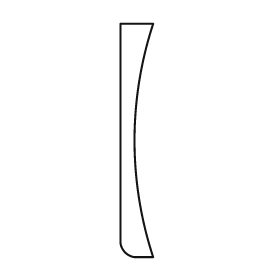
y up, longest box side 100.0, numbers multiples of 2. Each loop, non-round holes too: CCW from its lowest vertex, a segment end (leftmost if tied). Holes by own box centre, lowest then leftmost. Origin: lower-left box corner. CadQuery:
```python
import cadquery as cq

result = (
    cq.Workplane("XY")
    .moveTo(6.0, 0.0)
    .lineTo(14.0, 0.0)
    .threePointArc((6.0, 50.0), (14.0, 100.0))
    .lineTo(0.0, 100.0)
    .lineTo(0.0, 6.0)
    .threePointArc((2.0, 2.0), (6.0, 0.0))
    .close()
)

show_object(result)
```